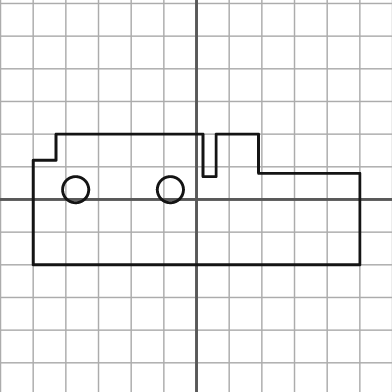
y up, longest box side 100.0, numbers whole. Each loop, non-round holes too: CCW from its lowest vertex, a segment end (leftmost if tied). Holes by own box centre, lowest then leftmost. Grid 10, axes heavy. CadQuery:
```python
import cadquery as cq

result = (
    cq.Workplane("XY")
    .moveTo(-50.0, -20.0)
    .lineTo(50.0, -20.0)
    .lineTo(50.0, 8.0)
    .lineTo(19.0, 8.0)
    .lineTo(19.0, 20.0)
    .lineTo(6.0, 20.0)
    .lineTo(6.0, 7.0)
    .lineTo(2.0, 7.0)
    .lineTo(2.0, 20.0)
    .lineTo(-43.0, 20.0)
    .lineTo(-43.0, 12.0)
    .lineTo(-50.0, 12.0)
    .close()
    .moveTo(-37.0, 3.0)
    .circle(4.0)
    .moveTo(-8.0, 3.0)
    .circle(4.0)
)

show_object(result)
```